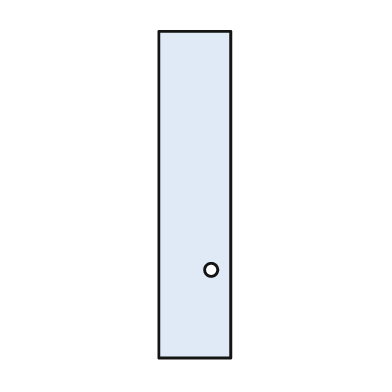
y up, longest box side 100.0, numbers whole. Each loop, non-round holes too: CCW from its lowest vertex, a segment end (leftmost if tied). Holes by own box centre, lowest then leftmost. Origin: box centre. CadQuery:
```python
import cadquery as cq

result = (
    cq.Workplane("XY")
    .moveTo(-11.0, -50.0)
    .lineTo(11.0, -50.0)
    .lineTo(11.0, 50.0)
    .lineTo(-11.0, 50.0)
    .close()
    .moveTo(5.0, -23.0)
    .circle(2.0)
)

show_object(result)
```